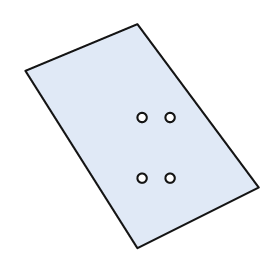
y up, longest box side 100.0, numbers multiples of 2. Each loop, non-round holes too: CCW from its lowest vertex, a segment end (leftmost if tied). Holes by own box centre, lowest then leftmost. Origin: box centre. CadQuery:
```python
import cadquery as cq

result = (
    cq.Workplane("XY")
    .moveTo(-2.0, -48.0)
    .lineTo(50.0, -22.0)
    .lineTo(-2.0, 48.0)
    .lineTo(-50.0, 28.0)
    .close()
    .moveTo(0.0, -18.0)
    .circle(2.0)
    .moveTo(12.0, -18.0)
    .circle(2.0)
    .moveTo(0.0, 8.0)
    .circle(2.0)
    .moveTo(12.0, 8.0)
    .circle(2.0)
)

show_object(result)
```